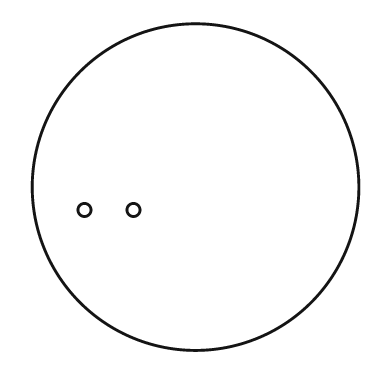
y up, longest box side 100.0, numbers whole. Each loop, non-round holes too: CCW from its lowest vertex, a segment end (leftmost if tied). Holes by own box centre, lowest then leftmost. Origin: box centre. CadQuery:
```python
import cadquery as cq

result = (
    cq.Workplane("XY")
    .moveTo(0.0, 0.0)
    .circle(50.0)
    .moveTo(-34.0, -7.0)
    .circle(2.0)
    .moveTo(-19.0, -7.0)
    .circle(2.0)
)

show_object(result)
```